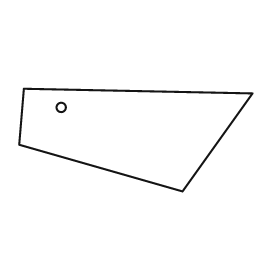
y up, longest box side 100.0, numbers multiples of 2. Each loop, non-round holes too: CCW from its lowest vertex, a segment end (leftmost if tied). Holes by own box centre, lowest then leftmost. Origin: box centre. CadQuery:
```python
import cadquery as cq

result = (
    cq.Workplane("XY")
    .moveTo(20.0, -22.0)
    .lineTo(50.0, 20.0)
    .lineTo(-48.0, 22.0)
    .lineTo(-50.0, -2.0)
    .close()
    .moveTo(-32.0, 14.0)
    .circle(2.0)
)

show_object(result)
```